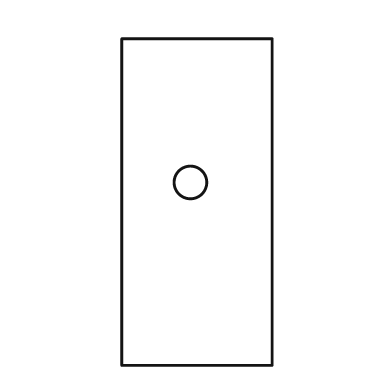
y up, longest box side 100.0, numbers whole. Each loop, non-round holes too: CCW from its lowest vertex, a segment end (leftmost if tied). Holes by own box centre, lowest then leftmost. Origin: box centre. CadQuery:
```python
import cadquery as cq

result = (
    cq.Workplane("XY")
    .moveTo(-23.0, -50.0)
    .lineTo(23.0, -50.0)
    .lineTo(23.0, 50.0)
    .lineTo(-23.0, 50.0)
    .close()
    .moveTo(-2.0, 6.0)
    .circle(5.0)
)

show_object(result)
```